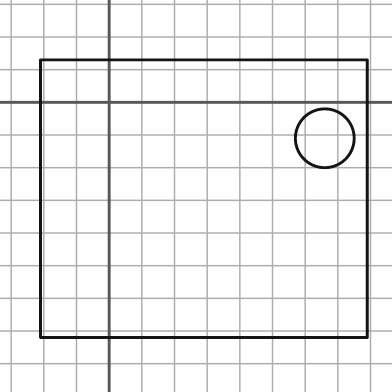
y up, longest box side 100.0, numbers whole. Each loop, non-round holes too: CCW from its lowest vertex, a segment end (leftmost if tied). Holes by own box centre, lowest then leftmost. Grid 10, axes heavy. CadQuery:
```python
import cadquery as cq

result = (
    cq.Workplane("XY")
    .moveTo(-21.0, -72.0)
    .lineTo(79.0, -72.0)
    .lineTo(79.0, 13.0)
    .lineTo(-21.0, 13.0)
    .close()
    .moveTo(66.0, -11.0)
    .circle(9.0)
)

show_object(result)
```